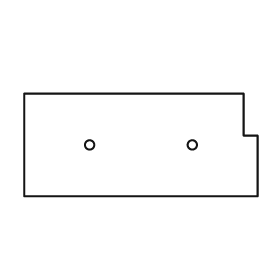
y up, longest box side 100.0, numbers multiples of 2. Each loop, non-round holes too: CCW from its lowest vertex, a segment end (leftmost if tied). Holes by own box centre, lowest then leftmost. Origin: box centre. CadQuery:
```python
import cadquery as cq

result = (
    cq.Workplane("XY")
    .moveTo(-50.0, -22.0)
    .lineTo(50.0, -22.0)
    .lineTo(50.0, 4.0)
    .lineTo(44.0, 4.0)
    .lineTo(44.0, 22.0)
    .lineTo(-50.0, 22.0)
    .close()
    .moveTo(-22.0, 0.0)
    .circle(2.0)
    .moveTo(22.0, 0.0)
    .circle(2.0)
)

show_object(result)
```